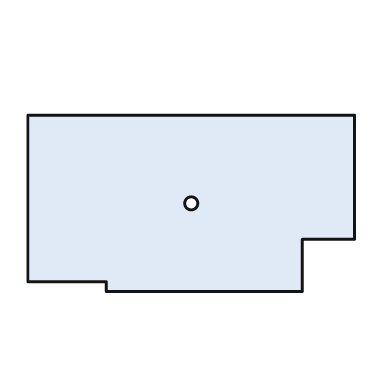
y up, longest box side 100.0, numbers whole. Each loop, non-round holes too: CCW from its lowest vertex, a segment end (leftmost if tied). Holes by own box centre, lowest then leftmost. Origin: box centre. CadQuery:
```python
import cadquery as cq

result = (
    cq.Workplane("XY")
    .moveTo(-26.0, -27.0)
    .lineTo(34.0, -27.0)
    .lineTo(34.0, -11.0)
    .lineTo(50.0, -11.0)
    .lineTo(50.0, 27.0)
    .lineTo(-50.0, 27.0)
    .lineTo(-50.0, -24.0)
    .lineTo(-26.0, -24.0)
    .close()
    .moveTo(0.0, 0.0)
    .circle(2.0)
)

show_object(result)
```